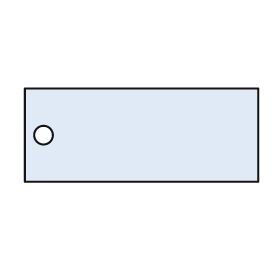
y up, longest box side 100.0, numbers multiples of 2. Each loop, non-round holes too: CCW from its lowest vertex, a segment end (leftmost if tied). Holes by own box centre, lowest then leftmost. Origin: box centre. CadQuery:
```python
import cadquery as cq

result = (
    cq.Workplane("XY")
    .moveTo(-50.0, -20.0)
    .lineTo(50.0, -20.0)
    .lineTo(50.0, 20.0)
    .lineTo(-50.0, 20.0)
    .close()
    .moveTo(-42.0, 0.0)
    .circle(4.0)
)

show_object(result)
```